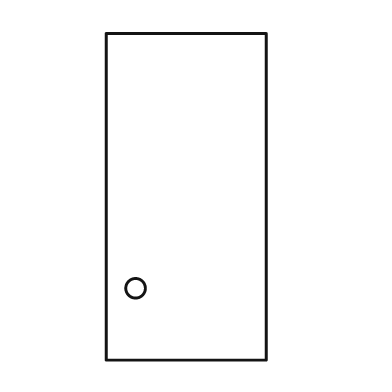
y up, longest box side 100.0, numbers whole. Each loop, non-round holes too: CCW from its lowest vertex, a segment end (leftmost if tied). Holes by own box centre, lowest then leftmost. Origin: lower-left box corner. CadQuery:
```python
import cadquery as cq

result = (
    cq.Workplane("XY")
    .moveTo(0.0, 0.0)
    .lineTo(49.0, 0.0)
    .lineTo(49.0, 100.0)
    .lineTo(0.0, 100.0)
    .close()
    .moveTo(9.0, 22.0)
    .circle(3.0)
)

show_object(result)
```